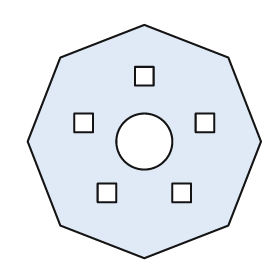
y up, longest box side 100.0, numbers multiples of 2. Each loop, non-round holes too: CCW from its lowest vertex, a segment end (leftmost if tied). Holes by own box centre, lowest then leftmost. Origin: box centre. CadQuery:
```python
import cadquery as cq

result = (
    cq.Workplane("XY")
    .moveTo(0.0, -50.0)
    .lineTo(36.0, -36.0)
    .lineTo(50.0, 0.0)
    .lineTo(36.0, 36.0)
    .lineTo(0.0, 50.0)
    .lineTo(-36.0, 36.0)
    .lineTo(-50.0, 0.0)
    .lineTo(-36.0, -36.0)
    .close()
    .moveTo(-20.0, -26.0)
    .lineTo(-12.0, -26.0)
    .lineTo(-12.0, -18.0)
    .lineTo(-20.0, -18.0)
    .close()
    .moveTo(12.0, -26.0)
    .lineTo(20.0, -26.0)
    .lineTo(20.0, -18.0)
    .lineTo(12.0, -18.0)
    .close()
    .moveTo(0.0, 0.0)
    .circle(12.0)
    .moveTo(-30.0, 4.0)
    .lineTo(-22.0, 4.0)
    .lineTo(-22.0, 12.0)
    .lineTo(-30.0, 12.0)
    .close()
    .moveTo(22.0, 4.0)
    .lineTo(30.0, 4.0)
    .lineTo(30.0, 12.0)
    .lineTo(22.0, 12.0)
    .close()
    .moveTo(-4.0, 24.0)
    .lineTo(4.0, 24.0)
    .lineTo(4.0, 32.0)
    .lineTo(-4.0, 32.0)
    .close()
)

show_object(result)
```